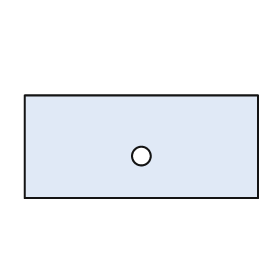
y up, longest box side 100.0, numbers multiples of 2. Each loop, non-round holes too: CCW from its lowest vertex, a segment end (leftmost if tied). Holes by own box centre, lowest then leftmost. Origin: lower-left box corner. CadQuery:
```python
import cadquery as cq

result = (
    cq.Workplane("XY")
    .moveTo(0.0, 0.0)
    .lineTo(100.0, 0.0)
    .lineTo(100.0, 44.0)
    .lineTo(0.0, 44.0)
    .close()
    .moveTo(50.0, 18.0)
    .circle(4.0)
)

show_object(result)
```